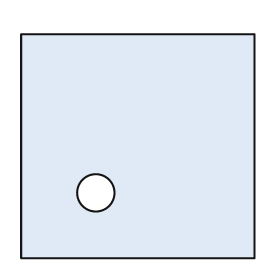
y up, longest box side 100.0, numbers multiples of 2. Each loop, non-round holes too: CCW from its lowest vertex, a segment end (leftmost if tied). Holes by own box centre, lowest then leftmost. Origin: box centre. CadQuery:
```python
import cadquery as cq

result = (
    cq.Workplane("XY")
    .moveTo(-50.0, -48.0)
    .lineTo(50.0, -48.0)
    .lineTo(50.0, 48.0)
    .lineTo(-50.0, 48.0)
    .close()
    .moveTo(-18.0, -20.0)
    .circle(8.0)
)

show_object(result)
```